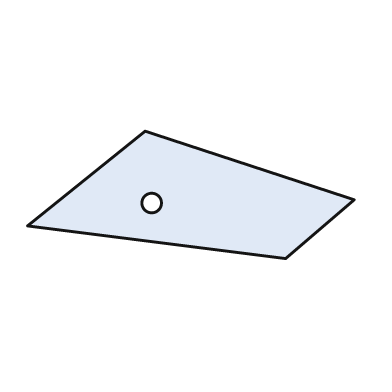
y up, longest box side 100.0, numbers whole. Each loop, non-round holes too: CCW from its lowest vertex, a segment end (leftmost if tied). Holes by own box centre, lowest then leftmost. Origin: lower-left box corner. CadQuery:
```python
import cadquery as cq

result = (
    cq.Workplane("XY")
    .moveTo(79.0, 0.0)
    .lineTo(100.0, 18.0)
    .lineTo(36.0, 39.0)
    .lineTo(0.0, 10.0)
    .close()
    .moveTo(38.0, 17.0)
    .circle(3.0)
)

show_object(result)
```